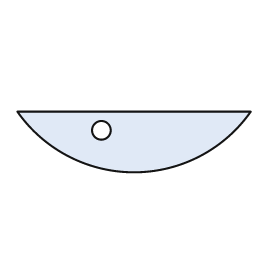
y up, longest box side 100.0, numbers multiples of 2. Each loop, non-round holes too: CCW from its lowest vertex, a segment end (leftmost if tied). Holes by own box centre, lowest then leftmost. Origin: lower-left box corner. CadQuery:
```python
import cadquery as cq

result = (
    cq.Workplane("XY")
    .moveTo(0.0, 26.0)
    .threePointArc((50.0, 0.0), (100.0, 26.0))
    .close()
    .moveTo(36.0, 18.0)
    .circle(4.0)
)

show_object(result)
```